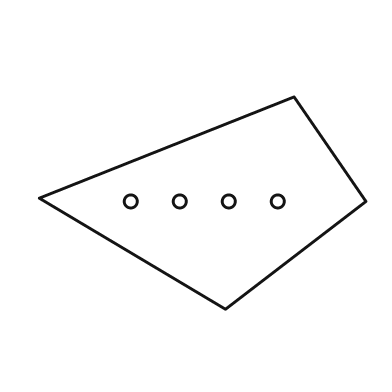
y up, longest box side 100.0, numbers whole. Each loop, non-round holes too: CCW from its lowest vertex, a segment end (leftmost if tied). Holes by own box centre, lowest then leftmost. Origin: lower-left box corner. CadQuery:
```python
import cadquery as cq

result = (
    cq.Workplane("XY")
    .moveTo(57.0, 0.0)
    .lineTo(100.0, 33.0)
    .lineTo(78.0, 65.0)
    .lineTo(0.0, 34.0)
    .close()
    .moveTo(28.0, 33.0)
    .circle(2.0)
    .moveTo(43.0, 33.0)
    .circle(2.0)
    .moveTo(58.0, 33.0)
    .circle(2.0)
    .moveTo(73.0, 33.0)
    .circle(2.0)
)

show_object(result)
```